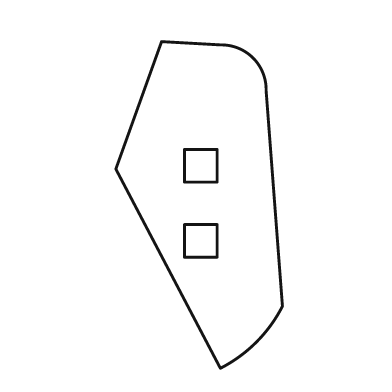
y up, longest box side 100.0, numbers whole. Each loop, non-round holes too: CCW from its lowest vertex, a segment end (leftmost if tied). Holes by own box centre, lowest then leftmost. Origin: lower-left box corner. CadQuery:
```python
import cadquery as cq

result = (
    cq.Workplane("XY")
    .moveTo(32.0, 0.0)
    .threePointArc((43.0, 8.0), (51.0, 19.0))
    .lineTo(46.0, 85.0)
    .threePointArc((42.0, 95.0), (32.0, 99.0))
    .lineTo(14.0, 100.0)
    .lineTo(0.0, 61.0)
    .close()
    .moveTo(21.0, 34.0)
    .lineTo(31.0, 34.0)
    .lineTo(31.0, 44.0)
    .lineTo(21.0, 44.0)
    .close()
    .moveTo(21.0, 57.0)
    .lineTo(31.0, 57.0)
    .lineTo(31.0, 67.0)
    .lineTo(21.0, 67.0)
    .close()
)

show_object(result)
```